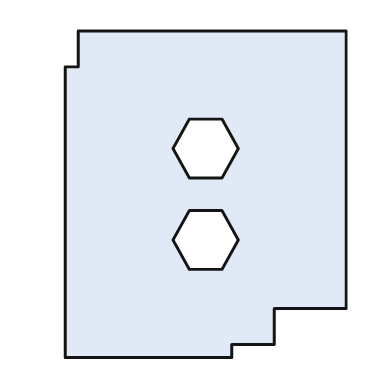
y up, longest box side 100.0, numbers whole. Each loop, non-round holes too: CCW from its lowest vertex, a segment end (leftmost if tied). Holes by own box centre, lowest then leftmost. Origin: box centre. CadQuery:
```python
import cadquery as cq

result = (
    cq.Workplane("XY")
    .moveTo(-43.0, -50.0)
    .lineTo(8.0, -50.0)
    .lineTo(8.0, -46.0)
    .lineTo(21.0, -46.0)
    .lineTo(21.0, -35.0)
    .lineTo(43.0, -35.0)
    .lineTo(43.0, 50.0)
    .lineTo(-39.0, 50.0)
    .lineTo(-39.0, 39.0)
    .lineTo(-43.0, 39.0)
    .close()
    .moveTo(-5.0, -23.0)
    .lineTo(5.0, -23.0)
    .lineTo(10.0, -14.0)
    .lineTo(5.0, -5.0)
    .lineTo(-5.0, -5.0)
    .lineTo(-10.0, -14.0)
    .close()
    .moveTo(-5.0, 5.0)
    .lineTo(5.0, 5.0)
    .lineTo(10.0, 14.0)
    .lineTo(5.0, 23.0)
    .lineTo(-5.0, 23.0)
    .lineTo(-10.0, 14.0)
    .close()
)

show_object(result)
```